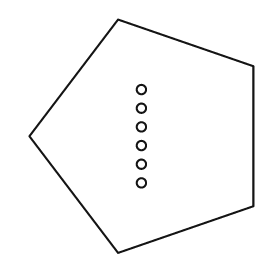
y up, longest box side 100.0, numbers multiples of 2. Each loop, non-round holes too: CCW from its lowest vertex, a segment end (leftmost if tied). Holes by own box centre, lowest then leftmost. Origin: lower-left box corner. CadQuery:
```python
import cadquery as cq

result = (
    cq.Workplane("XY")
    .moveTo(38.0, 0.0)
    .lineTo(96.0, 20.0)
    .lineTo(96.0, 80.0)
    .lineTo(38.0, 100.0)
    .lineTo(0.0, 50.0)
    .close()
    .moveTo(48.0, 30.0)
    .circle(2.0)
    .moveTo(48.0, 38.0)
    .circle(2.0)
    .moveTo(48.0, 46.0)
    .circle(2.0)
    .moveTo(48.0, 54.0)
    .circle(2.0)
    .moveTo(48.0, 62.0)
    .circle(2.0)
    .moveTo(48.0, 70.0)
    .circle(2.0)
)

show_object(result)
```